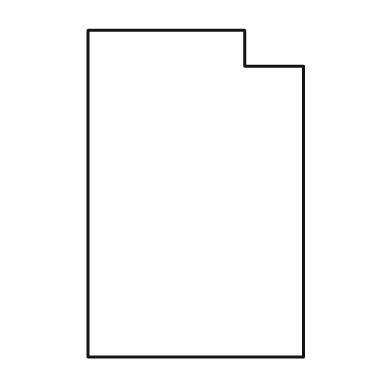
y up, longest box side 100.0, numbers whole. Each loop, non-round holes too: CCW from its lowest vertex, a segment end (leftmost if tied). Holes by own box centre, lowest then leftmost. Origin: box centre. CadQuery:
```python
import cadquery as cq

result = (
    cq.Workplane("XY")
    .moveTo(-33.0, -50.0)
    .lineTo(33.0, -50.0)
    .lineTo(33.0, 39.0)
    .lineTo(15.0, 39.0)
    .lineTo(15.0, 50.0)
    .lineTo(-33.0, 50.0)
    .close()
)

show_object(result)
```